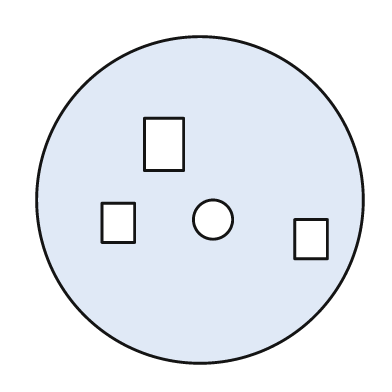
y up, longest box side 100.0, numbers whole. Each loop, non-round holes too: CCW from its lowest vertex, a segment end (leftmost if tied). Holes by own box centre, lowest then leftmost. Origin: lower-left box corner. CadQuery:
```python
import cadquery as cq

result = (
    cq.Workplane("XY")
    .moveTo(50.0, 50.0)
    .circle(50.0)
    .moveTo(79.0, 32.0)
    .lineTo(89.0, 32.0)
    .lineTo(89.0, 44.0)
    .lineTo(79.0, 44.0)
    .close()
    .moveTo(20.0, 37.0)
    .lineTo(30.0, 37.0)
    .lineTo(30.0, 49.0)
    .lineTo(20.0, 49.0)
    .close()
    .moveTo(54.0, 44.0)
    .circle(6.0)
    .moveTo(33.0, 59.0)
    .lineTo(45.0, 59.0)
    .lineTo(45.0, 75.0)
    .lineTo(33.0, 75.0)
    .close()
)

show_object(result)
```